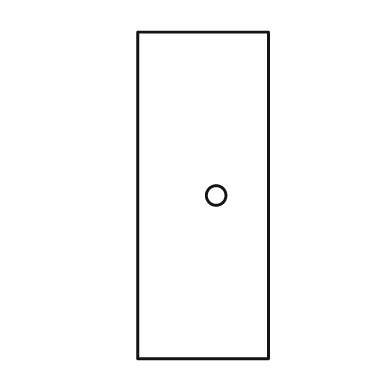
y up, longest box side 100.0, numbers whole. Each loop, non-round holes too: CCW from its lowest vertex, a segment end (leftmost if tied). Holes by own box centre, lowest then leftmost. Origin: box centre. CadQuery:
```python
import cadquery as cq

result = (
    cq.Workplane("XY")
    .moveTo(-20.0, -50.0)
    .lineTo(20.0, -50.0)
    .lineTo(20.0, 50.0)
    .lineTo(-20.0, 50.0)
    .close()
    .moveTo(4.0, 0.0)
    .circle(3.0)
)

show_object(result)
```